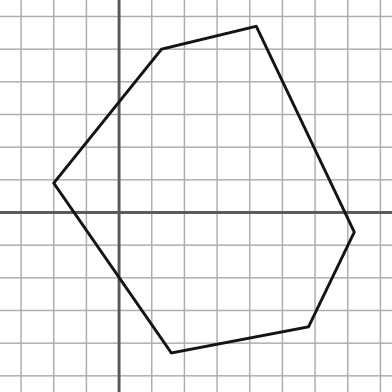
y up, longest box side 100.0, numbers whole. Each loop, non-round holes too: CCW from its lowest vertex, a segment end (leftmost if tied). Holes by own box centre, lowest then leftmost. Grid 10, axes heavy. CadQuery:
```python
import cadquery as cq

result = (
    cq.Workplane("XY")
    .moveTo(16.0, -43.0)
    .lineTo(58.0, -35.0)
    .lineTo(72.0, -6.0)
    .lineTo(42.0, 57.0)
    .lineTo(13.0, 50.0)
    .lineTo(-20.0, 9.0)
    .close()
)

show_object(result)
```